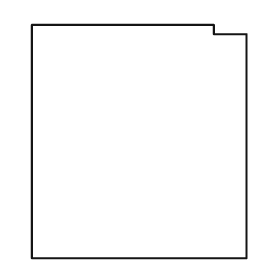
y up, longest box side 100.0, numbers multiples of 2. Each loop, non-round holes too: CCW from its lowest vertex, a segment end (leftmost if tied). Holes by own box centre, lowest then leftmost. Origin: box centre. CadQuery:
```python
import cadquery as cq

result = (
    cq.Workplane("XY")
    .moveTo(-46.0, -50.0)
    .lineTo(46.0, -50.0)
    .lineTo(46.0, 46.0)
    .lineTo(32.0, 46.0)
    .lineTo(32.0, 50.0)
    .lineTo(-46.0, 50.0)
    .close()
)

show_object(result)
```